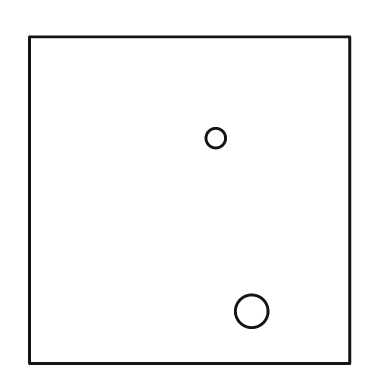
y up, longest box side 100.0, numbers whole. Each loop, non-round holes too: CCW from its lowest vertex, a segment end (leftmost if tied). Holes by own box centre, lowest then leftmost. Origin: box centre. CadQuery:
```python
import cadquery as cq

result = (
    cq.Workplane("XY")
    .moveTo(-49.0, -50.0)
    .lineTo(49.0, -50.0)
    .lineTo(49.0, 50.0)
    .lineTo(-49.0, 50.0)
    .close()
    .moveTo(19.0, -34.0)
    .circle(5.0)
    .moveTo(8.0, 19.0)
    .circle(3.0)
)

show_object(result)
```